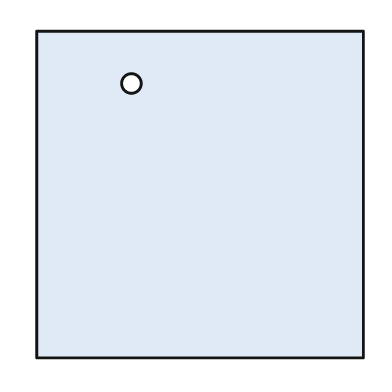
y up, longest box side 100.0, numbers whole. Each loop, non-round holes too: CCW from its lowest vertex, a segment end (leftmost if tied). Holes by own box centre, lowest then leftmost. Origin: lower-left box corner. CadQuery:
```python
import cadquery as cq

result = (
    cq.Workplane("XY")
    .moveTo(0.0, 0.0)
    .lineTo(100.0, 0.0)
    .lineTo(100.0, 100.0)
    .lineTo(0.0, 100.0)
    .close()
    .moveTo(29.0, 84.0)
    .circle(3.0)
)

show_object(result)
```